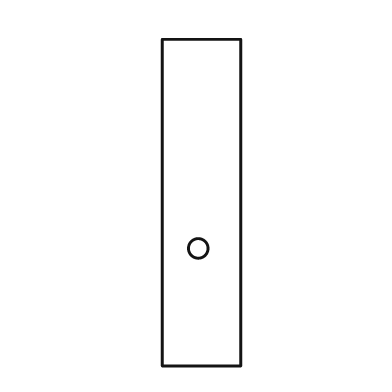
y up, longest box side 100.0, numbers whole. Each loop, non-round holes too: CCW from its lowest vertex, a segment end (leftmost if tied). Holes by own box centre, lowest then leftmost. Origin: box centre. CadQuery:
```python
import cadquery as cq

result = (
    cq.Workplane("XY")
    .moveTo(-12.0, -50.0)
    .lineTo(12.0, -50.0)
    .lineTo(12.0, 50.0)
    .lineTo(-12.0, 50.0)
    .close()
    .moveTo(-1.0, -14.0)
    .circle(3.0)
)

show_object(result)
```